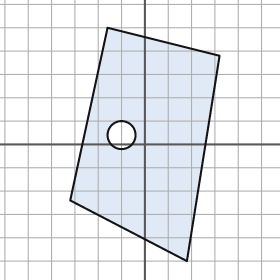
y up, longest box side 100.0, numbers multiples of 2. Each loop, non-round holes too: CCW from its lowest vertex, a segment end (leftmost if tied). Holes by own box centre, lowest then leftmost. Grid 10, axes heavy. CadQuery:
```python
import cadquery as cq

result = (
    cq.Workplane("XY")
    .moveTo(18.0, -50.0)
    .lineTo(32.0, 38.0)
    .lineTo(-16.0, 50.0)
    .lineTo(-32.0, -24.0)
    .close()
    .moveTo(-10.0, 4.0)
    .circle(6.0)
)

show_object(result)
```